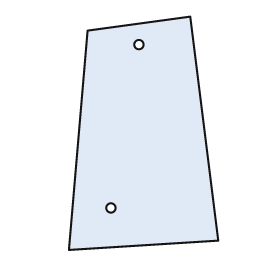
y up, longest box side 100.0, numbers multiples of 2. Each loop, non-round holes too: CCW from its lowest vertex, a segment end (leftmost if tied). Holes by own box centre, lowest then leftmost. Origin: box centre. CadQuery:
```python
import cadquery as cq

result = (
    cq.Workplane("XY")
    .moveTo(-32.0, -50.0)
    .lineTo(32.0, -46.0)
    .lineTo(20.0, 50.0)
    .lineTo(-24.0, 44.0)
    .close()
    .moveTo(-14.0, -32.0)
    .circle(2.0)
    .moveTo(-2.0, 38.0)
    .circle(2.0)
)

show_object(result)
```